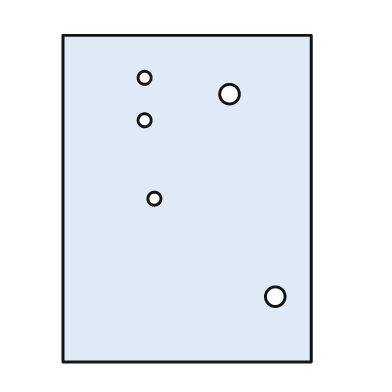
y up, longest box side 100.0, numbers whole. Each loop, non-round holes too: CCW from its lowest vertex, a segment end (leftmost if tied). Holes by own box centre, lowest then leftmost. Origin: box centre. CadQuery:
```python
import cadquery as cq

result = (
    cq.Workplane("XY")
    .moveTo(-38.0, -50.0)
    .lineTo(38.0, -50.0)
    .lineTo(38.0, 50.0)
    .lineTo(-38.0, 50.0)
    .close()
    .moveTo(27.0, -30.0)
    .circle(3.0)
    .moveTo(-10.0, 0.0)
    .circle(2.0)
    .moveTo(-13.0, 24.0)
    .circle(2.0)
    .moveTo(13.0, 32.0)
    .circle(3.0)
    .moveTo(-13.0, 37.0)
    .circle(2.0)
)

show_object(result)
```